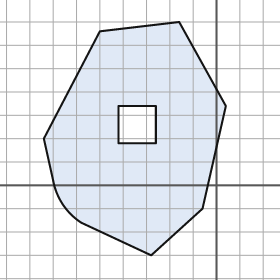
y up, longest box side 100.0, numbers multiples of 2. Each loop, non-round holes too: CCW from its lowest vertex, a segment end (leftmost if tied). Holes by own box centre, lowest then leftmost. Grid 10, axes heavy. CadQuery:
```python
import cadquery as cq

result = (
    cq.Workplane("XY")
    .moveTo(-28.0, -30.0)
    .lineTo(-6.0, -10.0)
    .lineTo(4.0, 34.0)
    .lineTo(-16.0, 70.0)
    .lineTo(-50.0, 66.0)
    .lineTo(-74.0, 20.0)
    .lineTo(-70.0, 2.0)
    .threePointArc((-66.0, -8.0), (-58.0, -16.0))
    .close()
    .moveTo(-42.0, 18.0)
    .lineTo(-26.0, 18.0)
    .lineTo(-26.0, 34.0)
    .lineTo(-42.0, 34.0)
    .close()
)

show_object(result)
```